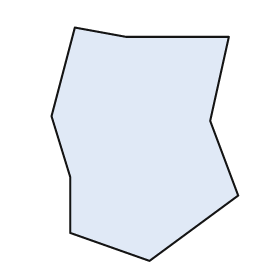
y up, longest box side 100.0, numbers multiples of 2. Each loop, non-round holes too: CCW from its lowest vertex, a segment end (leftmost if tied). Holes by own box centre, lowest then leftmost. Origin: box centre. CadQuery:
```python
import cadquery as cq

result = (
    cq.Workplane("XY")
    .moveTo(2.0, -50.0)
    .lineTo(40.0, -22.0)
    .lineTo(28.0, 10.0)
    .lineTo(36.0, 46.0)
    .lineTo(-8.0, 46.0)
    .lineTo(-30.0, 50.0)
    .lineTo(-40.0, 12.0)
    .lineTo(-32.0, -14.0)
    .lineTo(-32.0, -38.0)
    .close()
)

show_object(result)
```